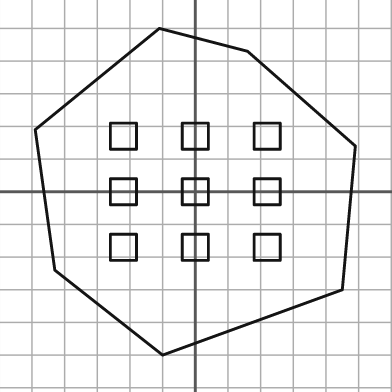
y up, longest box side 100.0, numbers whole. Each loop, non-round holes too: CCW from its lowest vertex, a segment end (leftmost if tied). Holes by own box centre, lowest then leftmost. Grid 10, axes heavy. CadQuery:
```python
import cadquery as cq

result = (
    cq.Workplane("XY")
    .moveTo(-10.0, -50.0)
    .lineTo(45.0, -30.0)
    .lineTo(49.0, 14.0)
    .lineTo(16.0, 43.0)
    .lineTo(-11.0, 50.0)
    .lineTo(-49.0, 19.0)
    .lineTo(-43.0, -24.0)
    .close()
    .moveTo(-26.0, -21.0)
    .lineTo(-18.0, -21.0)
    .lineTo(-18.0, -13.0)
    .lineTo(-26.0, -13.0)
    .close()
    .moveTo(-4.0, -21.0)
    .lineTo(4.0, -21.0)
    .lineTo(4.0, -13.0)
    .lineTo(-4.0, -13.0)
    .close()
    .moveTo(18.0, -21.0)
    .lineTo(26.0, -21.0)
    .lineTo(26.0, -13.0)
    .lineTo(18.0, -13.0)
    .close()
    .moveTo(-26.0, -4.0)
    .lineTo(-18.0, -4.0)
    .lineTo(-18.0, 4.0)
    .lineTo(-26.0, 4.0)
    .close()
    .moveTo(-4.0, -4.0)
    .lineTo(4.0, -4.0)
    .lineTo(4.0, 4.0)
    .lineTo(-4.0, 4.0)
    .close()
    .moveTo(18.0, -4.0)
    .lineTo(26.0, -4.0)
    .lineTo(26.0, 4.0)
    .lineTo(18.0, 4.0)
    .close()
    .moveTo(-26.0, 13.0)
    .lineTo(-18.0, 13.0)
    .lineTo(-18.0, 21.0)
    .lineTo(-26.0, 21.0)
    .close()
    .moveTo(-4.0, 13.0)
    .lineTo(4.0, 13.0)
    .lineTo(4.0, 21.0)
    .lineTo(-4.0, 21.0)
    .close()
    .moveTo(18.0, 13.0)
    .lineTo(26.0, 13.0)
    .lineTo(26.0, 21.0)
    .lineTo(18.0, 21.0)
    .close()
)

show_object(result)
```